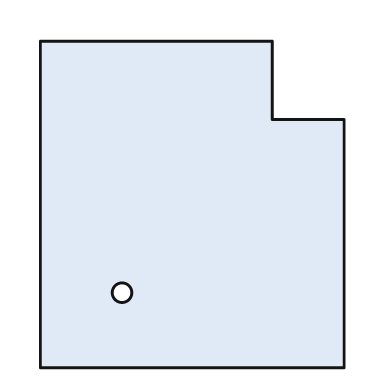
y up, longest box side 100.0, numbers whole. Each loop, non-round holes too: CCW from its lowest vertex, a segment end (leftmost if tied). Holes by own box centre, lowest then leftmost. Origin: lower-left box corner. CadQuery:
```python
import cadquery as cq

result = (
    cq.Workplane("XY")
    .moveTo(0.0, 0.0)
    .lineTo(93.0, 0.0)
    .lineTo(93.0, 76.0)
    .lineTo(71.0, 76.0)
    .lineTo(71.0, 100.0)
    .lineTo(0.0, 100.0)
    .close()
    .moveTo(25.0, 23.0)
    .circle(3.0)
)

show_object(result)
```